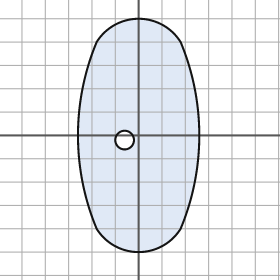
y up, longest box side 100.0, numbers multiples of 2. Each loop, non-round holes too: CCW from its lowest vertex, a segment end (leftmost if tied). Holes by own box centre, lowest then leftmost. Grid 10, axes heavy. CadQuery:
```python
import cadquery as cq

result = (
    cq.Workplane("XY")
    .moveTo(-18.0, -40.0)
    .threePointArc((0.0, -50.0), (18.0, -40.0))
    .threePointArc((26.0, 0.0), (18.0, 40.0))
    .threePointArc((0.0, 50.0), (-18.0, 40.0))
    .threePointArc((-26.0, 0.0), (-18.0, -40.0))
    .close()
    .moveTo(-6.0, -2.0)
    .circle(4.0)
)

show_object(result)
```